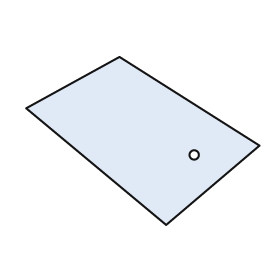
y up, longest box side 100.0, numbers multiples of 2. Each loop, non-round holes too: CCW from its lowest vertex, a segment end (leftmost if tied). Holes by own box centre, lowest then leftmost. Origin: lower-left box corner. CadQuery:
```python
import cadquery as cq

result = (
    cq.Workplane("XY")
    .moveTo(60.0, 0.0)
    .lineTo(100.0, 34.0)
    .lineTo(40.0, 72.0)
    .lineTo(0.0, 50.0)
    .close()
    .moveTo(72.0, 30.0)
    .circle(2.0)
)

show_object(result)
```